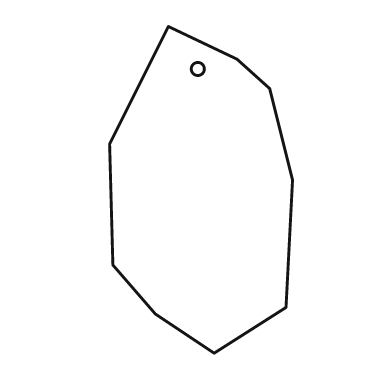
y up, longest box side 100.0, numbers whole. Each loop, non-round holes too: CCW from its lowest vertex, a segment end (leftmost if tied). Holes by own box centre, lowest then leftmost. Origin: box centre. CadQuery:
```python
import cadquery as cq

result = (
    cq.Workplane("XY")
    .moveTo(4.0, -50.0)
    .lineTo(26.0, -36.0)
    .lineTo(28.0, 3.0)
    .lineTo(21.0, 31.0)
    .lineTo(11.0, 40.0)
    .lineTo(-10.0, 50.0)
    .lineTo(-28.0, 14.0)
    .lineTo(-27.0, -23.0)
    .lineTo(-14.0, -38.0)
    .close()
    .moveTo(-1.0, 37.0)
    .circle(2.0)
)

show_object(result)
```